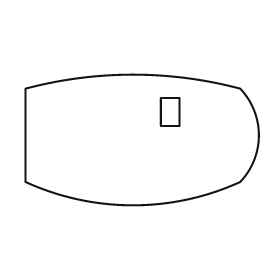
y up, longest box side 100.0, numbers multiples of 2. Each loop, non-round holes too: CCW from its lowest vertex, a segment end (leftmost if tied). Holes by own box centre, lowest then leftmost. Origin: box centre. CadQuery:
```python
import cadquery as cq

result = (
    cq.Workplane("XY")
    .moveTo(-50.0, -18.0)
    .threePointArc((-4.0, -28.0), (42.0, -18.0))
    .threePointArc((50.0, 2.0), (42.0, 22.0))
    .threePointArc((-4.0, 28.0), (-50.0, 22.0))
    .close()
    .moveTo(8.0, 6.0)
    .lineTo(16.0, 6.0)
    .lineTo(16.0, 18.0)
    .lineTo(8.0, 18.0)
    .close()
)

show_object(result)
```